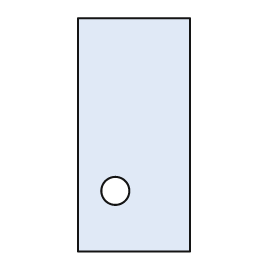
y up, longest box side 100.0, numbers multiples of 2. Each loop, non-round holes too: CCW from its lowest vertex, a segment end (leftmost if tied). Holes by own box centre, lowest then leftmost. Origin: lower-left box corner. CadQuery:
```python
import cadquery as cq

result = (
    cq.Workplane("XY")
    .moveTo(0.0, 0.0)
    .lineTo(48.0, 0.0)
    .lineTo(48.0, 100.0)
    .lineTo(0.0, 100.0)
    .close()
    .moveTo(16.0, 26.0)
    .circle(6.0)
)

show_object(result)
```